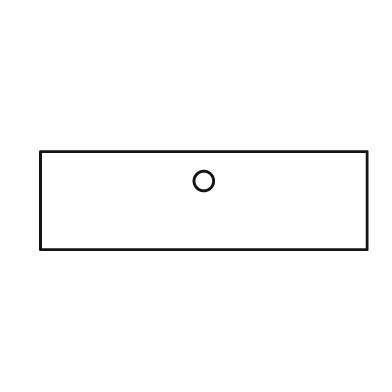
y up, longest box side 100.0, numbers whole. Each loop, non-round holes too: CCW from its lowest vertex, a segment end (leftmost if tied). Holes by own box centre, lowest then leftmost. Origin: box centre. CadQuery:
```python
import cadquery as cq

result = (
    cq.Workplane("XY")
    .moveTo(-50.0, -15.0)
    .lineTo(50.0, -15.0)
    .lineTo(50.0, 15.0)
    .lineTo(-50.0, 15.0)
    .close()
    .moveTo(0.0, 6.0)
    .circle(3.0)
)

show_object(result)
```